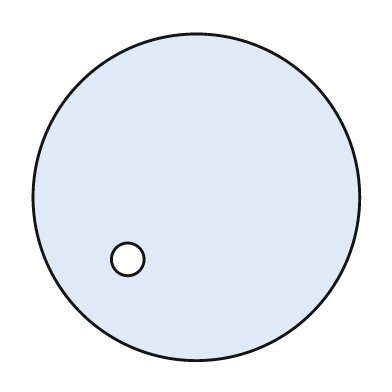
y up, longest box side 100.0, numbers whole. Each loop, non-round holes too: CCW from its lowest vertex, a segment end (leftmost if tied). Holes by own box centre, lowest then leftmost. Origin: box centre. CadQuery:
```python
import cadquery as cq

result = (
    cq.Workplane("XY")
    .moveTo(0.0, 0.0)
    .circle(50.0)
    .moveTo(-21.0, -19.0)
    .circle(5.0)
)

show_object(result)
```